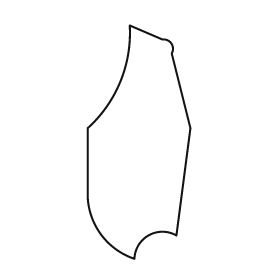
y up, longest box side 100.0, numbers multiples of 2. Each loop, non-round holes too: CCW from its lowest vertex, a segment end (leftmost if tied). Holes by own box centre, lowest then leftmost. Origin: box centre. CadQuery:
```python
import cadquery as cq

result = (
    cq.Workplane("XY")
    .moveTo(-2.0, -50.0)
    .threePointArc((4.0, -40.0), (16.0, -40.0))
    .lineTo(22.0, 6.0)
    .lineTo(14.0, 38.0)
    .threePointArc((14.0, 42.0), (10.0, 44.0))
    .lineTo(-4.0, 50.0)
    .threePointArc((-8.0, 26.0), (-22.0, 6.0))
    .lineTo(-22.0, -24.0)
    .threePointArc((-16.0, -40.0), (-2.0, -50.0))
    .close()
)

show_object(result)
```